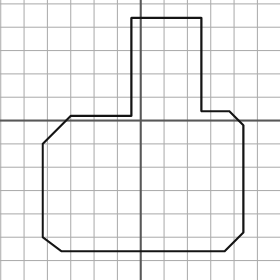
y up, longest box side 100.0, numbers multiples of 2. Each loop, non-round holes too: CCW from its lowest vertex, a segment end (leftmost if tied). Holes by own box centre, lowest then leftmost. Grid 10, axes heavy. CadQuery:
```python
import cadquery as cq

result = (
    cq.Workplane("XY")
    .moveTo(-34.0, -56.0)
    .lineTo(36.0, -56.0)
    .lineTo(44.0, -48.0)
    .lineTo(44.0, -2.0)
    .lineTo(38.0, 4.0)
    .lineTo(26.0, 4.0)
    .lineTo(26.0, 44.0)
    .lineTo(-4.0, 44.0)
    .lineTo(-4.0, 2.0)
    .lineTo(-30.0, 2.0)
    .lineTo(-42.0, -10.0)
    .lineTo(-42.0, -50.0)
    .close()
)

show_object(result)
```